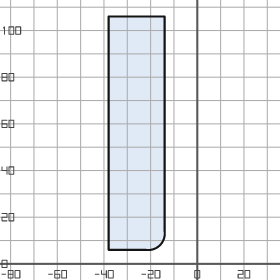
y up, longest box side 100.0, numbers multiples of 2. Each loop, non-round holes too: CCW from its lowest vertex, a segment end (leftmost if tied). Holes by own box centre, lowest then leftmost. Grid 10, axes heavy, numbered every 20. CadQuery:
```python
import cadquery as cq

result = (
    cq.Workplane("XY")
    .moveTo(-38.0, 6.0)
    .lineTo(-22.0, 6.0)
    .threePointArc((-16.0, 8.0), (-14.0, 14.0))
    .lineTo(-14.0, 106.0)
    .lineTo(-38.0, 106.0)
    .close()
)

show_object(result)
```